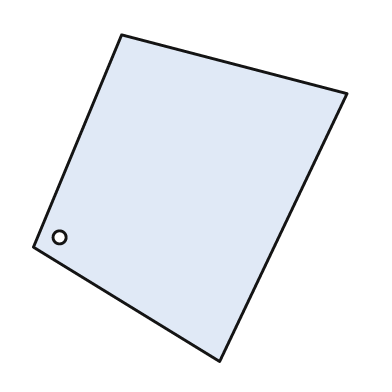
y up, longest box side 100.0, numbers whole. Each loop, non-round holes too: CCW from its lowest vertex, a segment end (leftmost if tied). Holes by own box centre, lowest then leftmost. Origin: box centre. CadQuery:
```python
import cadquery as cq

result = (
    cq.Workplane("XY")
    .moveTo(9.0, -50.0)
    .lineTo(48.0, 32.0)
    .lineTo(-21.0, 50.0)
    .lineTo(-48.0, -15.0)
    .close()
    .moveTo(-40.0, -12.0)
    .circle(2.0)
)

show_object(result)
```